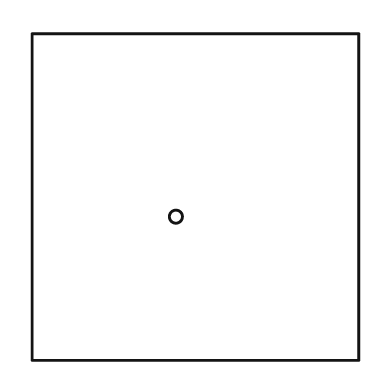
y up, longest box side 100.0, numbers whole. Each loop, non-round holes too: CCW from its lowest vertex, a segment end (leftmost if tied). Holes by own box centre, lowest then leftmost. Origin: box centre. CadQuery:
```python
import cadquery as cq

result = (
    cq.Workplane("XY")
    .moveTo(-50.0, -50.0)
    .lineTo(50.0, -50.0)
    .lineTo(50.0, 50.0)
    .lineTo(-50.0, 50.0)
    .close()
    .moveTo(-6.0, -6.0)
    .circle(2.0)
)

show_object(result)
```